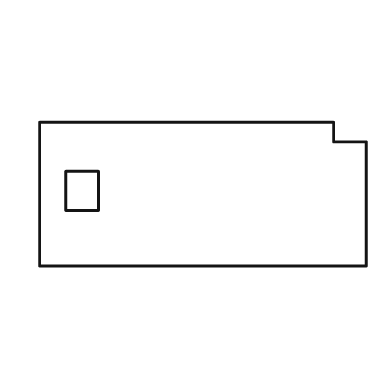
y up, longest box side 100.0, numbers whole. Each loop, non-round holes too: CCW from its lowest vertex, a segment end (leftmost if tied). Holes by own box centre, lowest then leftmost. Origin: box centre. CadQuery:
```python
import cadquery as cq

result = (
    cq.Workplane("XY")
    .moveTo(-50.0, -22.0)
    .lineTo(50.0, -22.0)
    .lineTo(50.0, 16.0)
    .lineTo(40.0, 16.0)
    .lineTo(40.0, 22.0)
    .lineTo(-50.0, 22.0)
    .close()
    .moveTo(-42.0, -5.0)
    .lineTo(-32.0, -5.0)
    .lineTo(-32.0, 7.0)
    .lineTo(-42.0, 7.0)
    .close()
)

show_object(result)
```